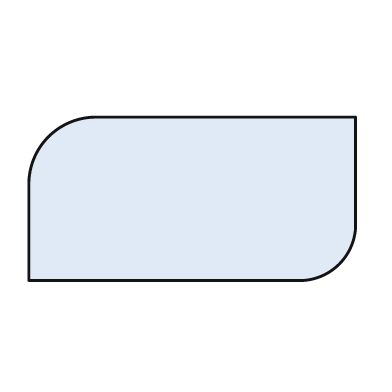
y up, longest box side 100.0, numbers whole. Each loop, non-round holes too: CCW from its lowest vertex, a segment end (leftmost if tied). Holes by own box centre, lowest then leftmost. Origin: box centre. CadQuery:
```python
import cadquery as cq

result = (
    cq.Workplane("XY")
    .moveTo(-50.0, -25.0)
    .lineTo(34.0, -25.0)
    .threePointArc((45.0, -20.0), (50.0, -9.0))
    .lineTo(50.0, 25.0)
    .lineTo(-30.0, 25.0)
    .threePointArc((-44.0, 19.0), (-50.0, 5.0))
    .close()
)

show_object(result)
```